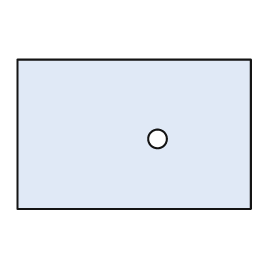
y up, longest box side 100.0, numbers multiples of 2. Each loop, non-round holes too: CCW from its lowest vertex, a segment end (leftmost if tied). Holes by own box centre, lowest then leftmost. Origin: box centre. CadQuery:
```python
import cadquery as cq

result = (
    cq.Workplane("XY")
    .moveTo(-50.0, -32.0)
    .lineTo(50.0, -32.0)
    .lineTo(50.0, 32.0)
    .lineTo(-50.0, 32.0)
    .close()
    .moveTo(10.0, -2.0)
    .circle(4.0)
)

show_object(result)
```